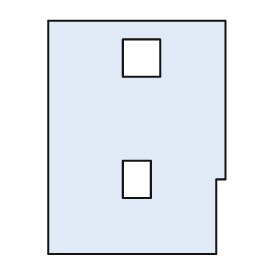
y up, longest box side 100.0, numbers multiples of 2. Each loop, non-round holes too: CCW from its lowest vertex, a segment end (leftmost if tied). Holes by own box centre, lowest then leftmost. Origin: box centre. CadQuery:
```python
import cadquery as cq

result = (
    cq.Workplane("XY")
    .moveTo(-38.0, -50.0)
    .lineTo(34.0, -50.0)
    .lineTo(34.0, -18.0)
    .lineTo(38.0, -18.0)
    .lineTo(38.0, 50.0)
    .lineTo(-38.0, 50.0)
    .close()
    .moveTo(-6.0, -26.0)
    .lineTo(6.0, -26.0)
    .lineTo(6.0, -10.0)
    .lineTo(-6.0, -10.0)
    .close()
    .moveTo(-6.0, 26.0)
    .lineTo(10.0, 26.0)
    .lineTo(10.0, 42.0)
    .lineTo(-6.0, 42.0)
    .close()
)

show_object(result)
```